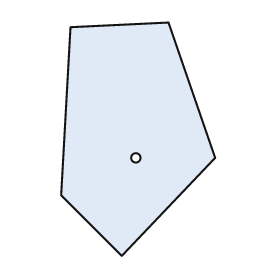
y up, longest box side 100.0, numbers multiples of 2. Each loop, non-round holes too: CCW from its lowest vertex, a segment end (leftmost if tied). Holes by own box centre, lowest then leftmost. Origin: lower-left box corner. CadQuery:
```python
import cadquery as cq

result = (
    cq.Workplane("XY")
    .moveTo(26.0, 0.0)
    .lineTo(66.0, 42.0)
    .lineTo(46.0, 100.0)
    .lineTo(4.0, 98.0)
    .lineTo(0.0, 26.0)
    .close()
    .moveTo(32.0, 42.0)
    .circle(2.0)
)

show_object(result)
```